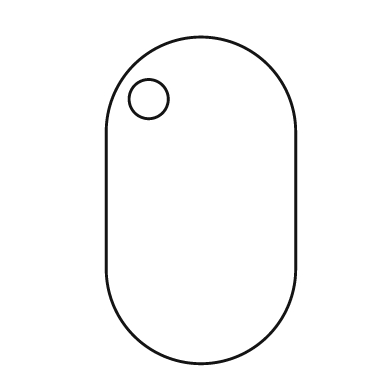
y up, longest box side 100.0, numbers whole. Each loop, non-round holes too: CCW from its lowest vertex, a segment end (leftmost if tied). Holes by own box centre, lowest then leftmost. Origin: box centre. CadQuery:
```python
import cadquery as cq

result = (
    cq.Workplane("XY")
    .moveTo(-29.0, -21.0)
    .threePointArc((0.0, -50.0), (29.0, -21.0))
    .lineTo(29.0, 21.0)
    .threePointArc((0.0, 50.0), (-29.0, 21.0))
    .close()
    .moveTo(-16.0, 31.0)
    .circle(6.0)
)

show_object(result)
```